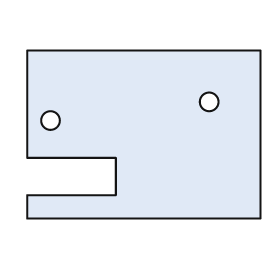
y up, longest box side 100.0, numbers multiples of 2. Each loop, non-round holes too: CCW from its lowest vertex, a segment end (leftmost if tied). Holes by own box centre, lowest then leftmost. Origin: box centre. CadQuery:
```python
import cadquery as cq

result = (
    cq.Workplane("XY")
    .moveTo(-50.0, -36.0)
    .lineTo(50.0, -36.0)
    .lineTo(50.0, 36.0)
    .lineTo(-50.0, 36.0)
    .lineTo(-50.0, -10.0)
    .lineTo(-12.0, -10.0)
    .lineTo(-12.0, -26.0)
    .lineTo(-50.0, -26.0)
    .close()
    .moveTo(-40.0, 6.0)
    .circle(4.0)
    .moveTo(28.0, 14.0)
    .circle(4.0)
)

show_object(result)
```